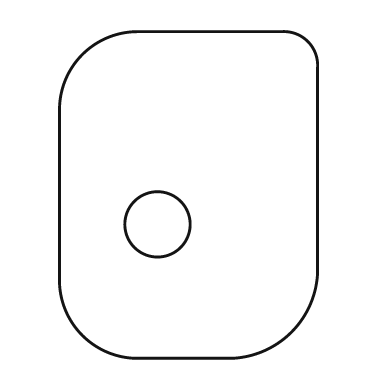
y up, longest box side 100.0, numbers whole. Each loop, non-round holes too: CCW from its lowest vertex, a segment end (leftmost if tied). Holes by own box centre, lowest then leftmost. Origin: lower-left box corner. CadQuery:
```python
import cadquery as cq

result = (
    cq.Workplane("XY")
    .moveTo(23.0, 0.0)
    .lineTo(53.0, 0.0)
    .threePointArc((71.0, 8.0), (79.0, 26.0))
    .lineTo(79.0, 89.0)
    .threePointArc((76.0, 97.0), (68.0, 100.0))
    .lineTo(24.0, 100.0)
    .threePointArc((7.0, 93.0), (0.0, 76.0))
    .lineTo(0.0, 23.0)
    .threePointArc((7.0, 7.0), (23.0, 0.0))
    .close()
    .moveTo(30.0, 41.0)
    .circle(10.0)
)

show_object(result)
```